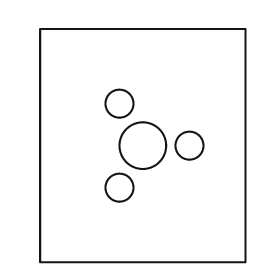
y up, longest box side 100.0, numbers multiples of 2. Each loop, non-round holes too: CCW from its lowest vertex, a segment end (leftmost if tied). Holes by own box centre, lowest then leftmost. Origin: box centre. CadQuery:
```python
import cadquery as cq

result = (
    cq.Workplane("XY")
    .moveTo(-44.0, -50.0)
    .lineTo(44.0, -50.0)
    .lineTo(44.0, 50.0)
    .lineTo(-44.0, 50.0)
    .close()
    .moveTo(-10.0, -18.0)
    .circle(6.0)
    .moveTo(0.0, 0.0)
    .circle(10.0)
    .moveTo(20.0, 0.0)
    .circle(6.0)
    .moveTo(-10.0, 18.0)
    .circle(6.0)
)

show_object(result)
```